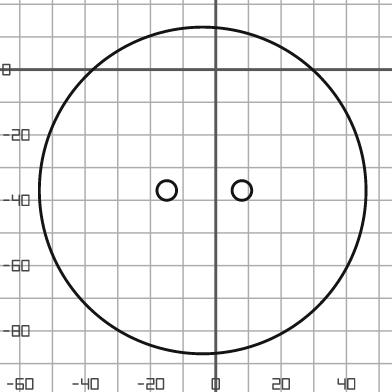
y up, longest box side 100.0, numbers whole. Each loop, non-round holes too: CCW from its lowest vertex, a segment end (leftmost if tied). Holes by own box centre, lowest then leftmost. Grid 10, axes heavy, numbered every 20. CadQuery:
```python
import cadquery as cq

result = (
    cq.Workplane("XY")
    .moveTo(-4.0, -37.0)
    .circle(50.0)
    .moveTo(-15.0, -37.0)
    .circle(3.0)
    .moveTo(8.0, -37.0)
    .circle(3.0)
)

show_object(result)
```